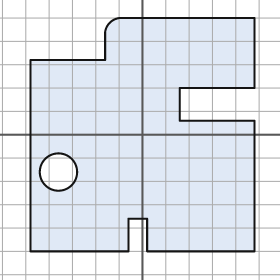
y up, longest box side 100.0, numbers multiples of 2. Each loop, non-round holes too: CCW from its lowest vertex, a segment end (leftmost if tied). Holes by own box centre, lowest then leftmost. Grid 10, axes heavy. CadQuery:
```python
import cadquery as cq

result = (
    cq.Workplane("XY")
    .moveTo(-48.0, -50.0)
    .lineTo(-6.0, -50.0)
    .lineTo(-6.0, -36.0)
    .lineTo(2.0, -36.0)
    .lineTo(2.0, -50.0)
    .lineTo(48.0, -50.0)
    .lineTo(48.0, 6.0)
    .lineTo(16.0, 6.0)
    .lineTo(16.0, 20.0)
    .lineTo(48.0, 20.0)
    .lineTo(48.0, 50.0)
    .lineTo(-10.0, 50.0)
    .threePointArc((-14.0, 48.0), (-16.0, 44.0))
    .lineTo(-16.0, 32.0)
    .lineTo(-48.0, 32.0)
    .close()
    .moveTo(-36.0, -16.0)
    .circle(8.0)
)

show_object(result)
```